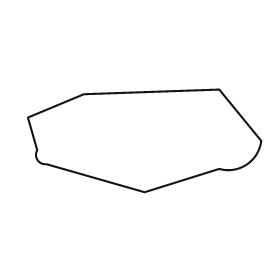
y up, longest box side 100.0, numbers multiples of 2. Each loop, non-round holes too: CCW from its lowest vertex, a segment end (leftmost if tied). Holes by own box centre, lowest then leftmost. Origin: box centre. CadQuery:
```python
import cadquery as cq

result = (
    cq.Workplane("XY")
    .moveTo(0.0, -22.0)
    .lineTo(32.0, -12.0)
    .threePointArc((44.0, -10.0), (50.0, 0.0))
    .lineTo(32.0, 22.0)
    .lineTo(-26.0, 20.0)
    .lineTo(-50.0, 10.0)
    .lineTo(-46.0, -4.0)
    .threePointArc((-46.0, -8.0), (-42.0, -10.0))
    .close()
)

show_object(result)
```